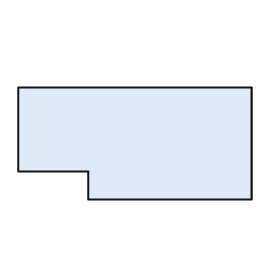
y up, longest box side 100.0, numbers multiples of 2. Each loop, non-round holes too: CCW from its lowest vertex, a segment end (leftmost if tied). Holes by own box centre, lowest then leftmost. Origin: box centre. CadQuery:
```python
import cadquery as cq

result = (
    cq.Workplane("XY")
    .moveTo(-20.0, -24.0)
    .lineTo(50.0, -24.0)
    .lineTo(50.0, 24.0)
    .lineTo(-50.0, 24.0)
    .lineTo(-50.0, -12.0)
    .lineTo(-20.0, -12.0)
    .close()
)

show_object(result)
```